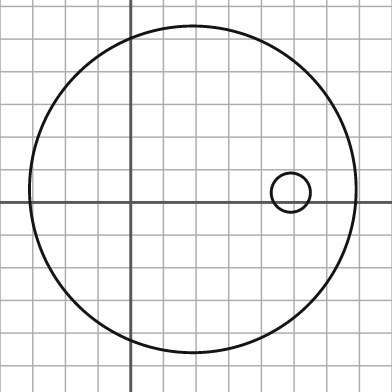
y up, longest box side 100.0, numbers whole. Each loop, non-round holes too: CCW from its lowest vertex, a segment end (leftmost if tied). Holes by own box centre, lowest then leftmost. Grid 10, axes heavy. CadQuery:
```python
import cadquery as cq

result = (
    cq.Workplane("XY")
    .moveTo(19.0, 4.0)
    .circle(50.0)
    .moveTo(49.0, 3.0)
    .circle(6.0)
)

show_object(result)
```